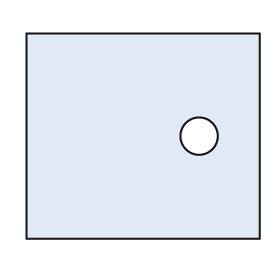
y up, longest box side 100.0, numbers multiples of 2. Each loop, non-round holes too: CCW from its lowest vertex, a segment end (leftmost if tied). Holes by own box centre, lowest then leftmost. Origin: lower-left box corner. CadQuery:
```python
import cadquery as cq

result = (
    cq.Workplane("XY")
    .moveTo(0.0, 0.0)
    .lineTo(100.0, 0.0)
    .lineTo(100.0, 88.0)
    .lineTo(0.0, 88.0)
    .close()
    .moveTo(74.0, 44.0)
    .circle(8.0)
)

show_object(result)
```